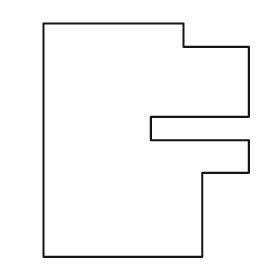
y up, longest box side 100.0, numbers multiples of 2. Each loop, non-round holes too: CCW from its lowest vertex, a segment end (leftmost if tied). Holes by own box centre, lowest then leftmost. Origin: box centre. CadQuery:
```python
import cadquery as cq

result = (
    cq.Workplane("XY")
    .moveTo(-44.0, -50.0)
    .lineTo(24.0, -50.0)
    .lineTo(24.0, -14.0)
    .lineTo(44.0, -14.0)
    .lineTo(44.0, 0.0)
    .lineTo(2.0, 0.0)
    .lineTo(2.0, 10.0)
    .lineTo(44.0, 10.0)
    .lineTo(44.0, 40.0)
    .lineTo(16.0, 40.0)
    .lineTo(16.0, 50.0)
    .lineTo(-44.0, 50.0)
    .close()
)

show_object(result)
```